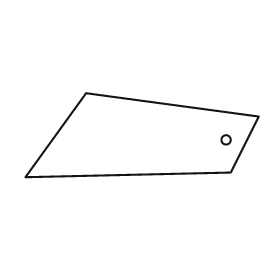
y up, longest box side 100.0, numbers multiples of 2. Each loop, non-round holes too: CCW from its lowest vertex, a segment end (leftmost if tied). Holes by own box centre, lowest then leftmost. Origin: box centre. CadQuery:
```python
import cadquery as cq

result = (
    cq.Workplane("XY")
    .moveTo(-50.0, -18.0)
    .lineTo(38.0, -16.0)
    .lineTo(50.0, 8.0)
    .lineTo(-24.0, 18.0)
    .close()
    .moveTo(36.0, -2.0)
    .circle(2.0)
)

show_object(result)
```